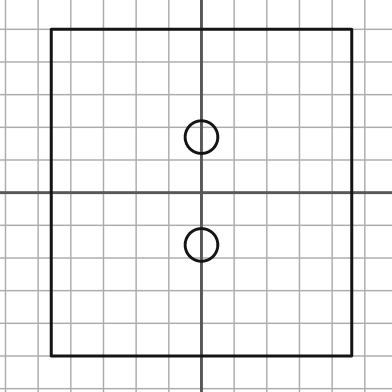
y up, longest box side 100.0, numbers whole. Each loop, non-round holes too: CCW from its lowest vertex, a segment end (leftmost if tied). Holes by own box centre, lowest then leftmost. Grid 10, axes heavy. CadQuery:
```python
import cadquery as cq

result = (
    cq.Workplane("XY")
    .moveTo(-46.0, -50.0)
    .lineTo(46.0, -50.0)
    .lineTo(46.0, 50.0)
    .lineTo(-46.0, 50.0)
    .close()
    .moveTo(0.0, -16.0)
    .circle(5.0)
    .moveTo(0.0, 17.0)
    .circle(5.0)
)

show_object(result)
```